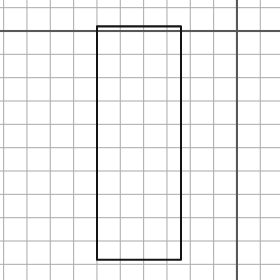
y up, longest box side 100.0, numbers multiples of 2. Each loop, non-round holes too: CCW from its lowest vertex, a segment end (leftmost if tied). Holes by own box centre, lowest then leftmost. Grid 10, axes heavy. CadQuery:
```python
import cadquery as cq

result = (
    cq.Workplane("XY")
    .moveTo(-60.0, -98.0)
    .lineTo(-24.0, -98.0)
    .lineTo(-24.0, 2.0)
    .lineTo(-60.0, 2.0)
    .close()
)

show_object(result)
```